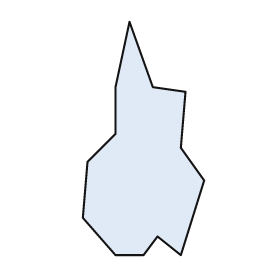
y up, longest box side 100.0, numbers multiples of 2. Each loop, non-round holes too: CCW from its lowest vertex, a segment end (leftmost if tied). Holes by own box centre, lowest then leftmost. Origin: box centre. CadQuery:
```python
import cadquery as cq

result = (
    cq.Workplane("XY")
    .moveTo(-12.0, -50.0)
    .lineTo(0.0, -50.0)
    .lineTo(6.0, -42.0)
    .lineTo(16.0, -50.0)
    .lineTo(26.0, -18.0)
    .lineTo(16.0, -4.0)
    .lineTo(18.0, 20.0)
    .lineTo(4.0, 22.0)
    .lineTo(-6.0, 50.0)
    .lineTo(-12.0, 22.0)
    .lineTo(-12.0, 2.0)
    .lineTo(-24.0, -10.0)
    .lineTo(-26.0, -34.0)
    .close()
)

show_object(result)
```